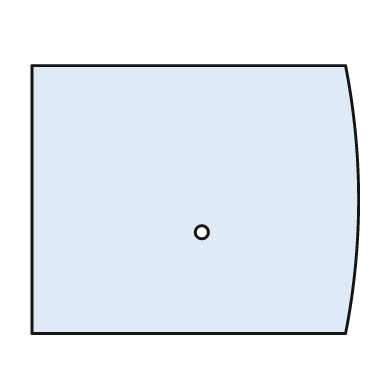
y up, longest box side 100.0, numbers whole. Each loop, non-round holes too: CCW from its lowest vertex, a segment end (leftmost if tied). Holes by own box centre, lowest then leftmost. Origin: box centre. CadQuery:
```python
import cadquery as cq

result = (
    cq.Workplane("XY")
    .moveTo(-50.0, -41.0)
    .lineTo(46.0, -41.0)
    .threePointArc((50.0, 0.0), (46.0, 41.0))
    .lineTo(-50.0, 41.0)
    .close()
    .moveTo(2.0, -10.0)
    .circle(2.0)
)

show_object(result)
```